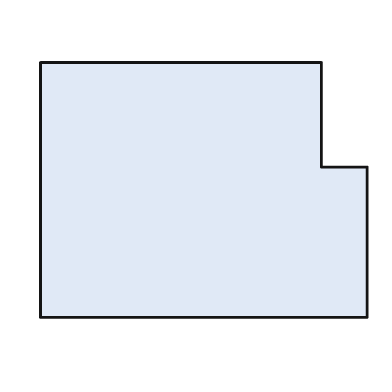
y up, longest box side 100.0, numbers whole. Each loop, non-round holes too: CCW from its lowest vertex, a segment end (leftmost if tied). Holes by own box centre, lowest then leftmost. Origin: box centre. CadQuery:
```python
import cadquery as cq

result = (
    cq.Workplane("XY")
    .moveTo(-50.0, -39.0)
    .lineTo(50.0, -39.0)
    .lineTo(50.0, 7.0)
    .lineTo(36.0, 7.0)
    .lineTo(36.0, 39.0)
    .lineTo(-50.0, 39.0)
    .close()
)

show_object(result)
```